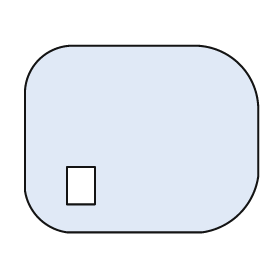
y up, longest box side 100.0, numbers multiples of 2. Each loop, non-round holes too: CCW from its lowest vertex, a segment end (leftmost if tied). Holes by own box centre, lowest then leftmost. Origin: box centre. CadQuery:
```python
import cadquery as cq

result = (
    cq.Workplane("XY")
    .moveTo(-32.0, -40.0)
    .lineTo(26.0, -40.0)
    .threePointArc((42.0, -32.0), (50.0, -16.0))
    .lineTo(50.0, 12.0)
    .threePointArc((42.0, 32.0), (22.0, 40.0))
    .lineTo(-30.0, 40.0)
    .threePointArc((-44.0, 34.0), (-50.0, 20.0))
    .lineTo(-50.0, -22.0)
    .threePointArc((-44.0, -34.0), (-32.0, -40.0))
    .close()
    .moveTo(-32.0, -28.0)
    .lineTo(-20.0, -28.0)
    .lineTo(-20.0, -12.0)
    .lineTo(-32.0, -12.0)
    .close()
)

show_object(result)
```